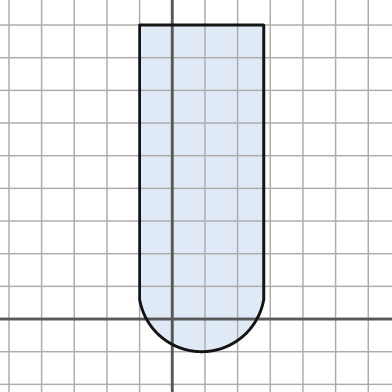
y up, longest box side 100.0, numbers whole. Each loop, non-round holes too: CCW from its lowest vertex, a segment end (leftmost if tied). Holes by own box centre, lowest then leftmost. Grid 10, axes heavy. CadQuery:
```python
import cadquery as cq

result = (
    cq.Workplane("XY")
    .moveTo(-10.0, 6.0)
    .threePointArc((9.0, -10.0), (28.0, 6.0))
    .lineTo(28.0, 90.0)
    .lineTo(-10.0, 90.0)
    .close()
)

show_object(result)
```